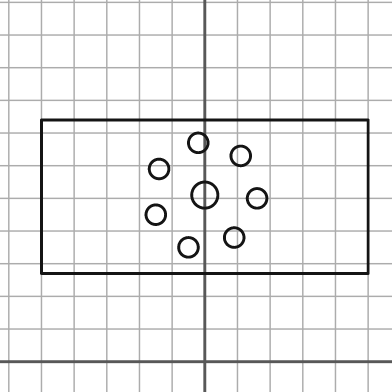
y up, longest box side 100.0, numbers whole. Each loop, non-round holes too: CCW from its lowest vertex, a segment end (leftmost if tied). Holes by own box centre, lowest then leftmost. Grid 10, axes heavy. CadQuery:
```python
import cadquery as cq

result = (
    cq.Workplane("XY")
    .moveTo(-50.0, 27.0)
    .lineTo(50.0, 27.0)
    .lineTo(50.0, 74.0)
    .lineTo(-50.0, 74.0)
    .close()
    .moveTo(-5.0, 35.0)
    .circle(3.0)
    .moveTo(9.0, 38.0)
    .circle(3.0)
    .moveTo(-15.0, 45.0)
    .circle(3.0)
    .moveTo(16.0, 50.0)
    .circle(3.0)
    .moveTo(0.0, 51.0)
    .circle(4.0)
    .moveTo(-14.0, 59.0)
    .circle(3.0)
    .moveTo(11.0, 63.0)
    .circle(3.0)
    .moveTo(-2.0, 67.0)
    .circle(3.0)
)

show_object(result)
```